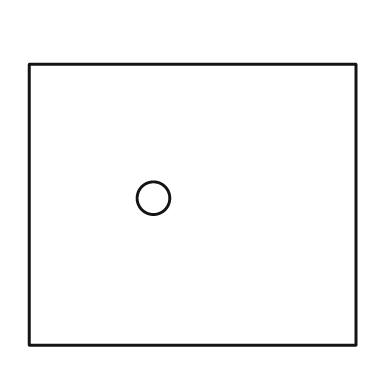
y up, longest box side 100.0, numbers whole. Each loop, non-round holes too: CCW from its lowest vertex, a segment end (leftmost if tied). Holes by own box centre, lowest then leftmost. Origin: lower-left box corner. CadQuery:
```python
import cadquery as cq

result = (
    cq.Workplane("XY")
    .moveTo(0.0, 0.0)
    .lineTo(100.0, 0.0)
    .lineTo(100.0, 86.0)
    .lineTo(0.0, 86.0)
    .close()
    .moveTo(38.0, 45.0)
    .circle(5.0)
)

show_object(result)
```